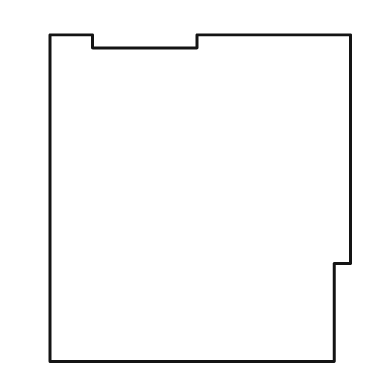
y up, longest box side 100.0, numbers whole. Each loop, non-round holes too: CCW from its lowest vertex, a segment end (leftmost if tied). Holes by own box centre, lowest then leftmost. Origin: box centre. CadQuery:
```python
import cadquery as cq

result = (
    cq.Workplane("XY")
    .moveTo(-46.0, -50.0)
    .lineTo(41.0, -50.0)
    .lineTo(41.0, -20.0)
    .lineTo(46.0, -20.0)
    .lineTo(46.0, 50.0)
    .lineTo(-1.0, 50.0)
    .lineTo(-1.0, 46.0)
    .lineTo(-33.0, 46.0)
    .lineTo(-33.0, 50.0)
    .lineTo(-46.0, 50.0)
    .close()
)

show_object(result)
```